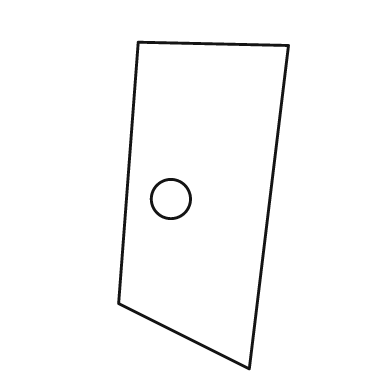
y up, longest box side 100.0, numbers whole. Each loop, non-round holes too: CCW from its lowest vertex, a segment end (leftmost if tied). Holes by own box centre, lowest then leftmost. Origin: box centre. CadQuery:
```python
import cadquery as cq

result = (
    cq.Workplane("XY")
    .moveTo(14.0, -50.0)
    .lineTo(26.0, 49.0)
    .lineTo(-20.0, 50.0)
    .lineTo(-26.0, -30.0)
    .close()
    .moveTo(-10.0, 2.0)
    .circle(6.0)
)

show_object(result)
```